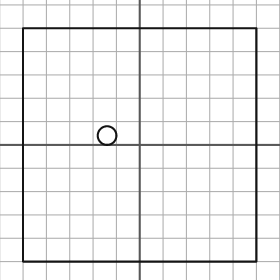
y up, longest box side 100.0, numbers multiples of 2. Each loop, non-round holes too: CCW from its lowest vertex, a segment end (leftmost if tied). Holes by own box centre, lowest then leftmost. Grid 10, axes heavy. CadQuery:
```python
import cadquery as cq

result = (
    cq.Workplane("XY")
    .moveTo(-50.0, -50.0)
    .lineTo(50.0, -50.0)
    .lineTo(50.0, 50.0)
    .lineTo(-50.0, 50.0)
    .close()
    .moveTo(-14.0, 4.0)
    .circle(4.0)
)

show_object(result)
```